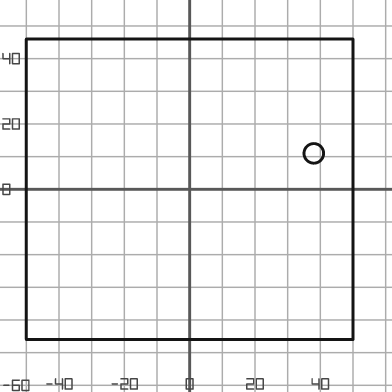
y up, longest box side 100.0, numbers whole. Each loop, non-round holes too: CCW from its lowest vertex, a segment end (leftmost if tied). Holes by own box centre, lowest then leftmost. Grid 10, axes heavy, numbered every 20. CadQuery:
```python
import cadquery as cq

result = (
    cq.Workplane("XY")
    .moveTo(-50.0, -46.0)
    .lineTo(50.0, -46.0)
    .lineTo(50.0, 46.0)
    .lineTo(-50.0, 46.0)
    .close()
    .moveTo(38.0, 11.0)
    .circle(3.0)
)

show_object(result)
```